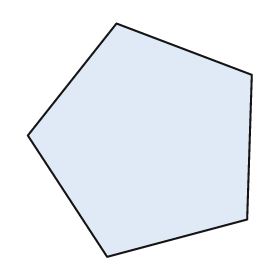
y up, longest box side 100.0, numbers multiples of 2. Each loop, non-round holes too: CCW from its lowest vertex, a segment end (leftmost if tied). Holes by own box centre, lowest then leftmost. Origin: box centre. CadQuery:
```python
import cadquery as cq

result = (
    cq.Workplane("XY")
    .moveTo(-14.0, -50.0)
    .lineTo(46.0, -34.0)
    .lineTo(48.0, 28.0)
    .lineTo(-10.0, 50.0)
    .lineTo(-48.0, 2.0)
    .close()
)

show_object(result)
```